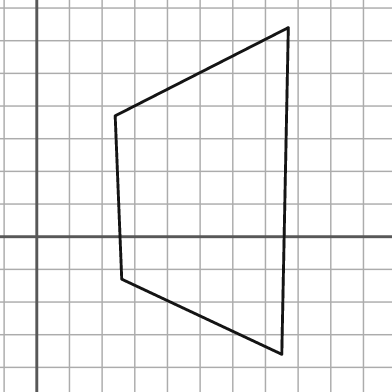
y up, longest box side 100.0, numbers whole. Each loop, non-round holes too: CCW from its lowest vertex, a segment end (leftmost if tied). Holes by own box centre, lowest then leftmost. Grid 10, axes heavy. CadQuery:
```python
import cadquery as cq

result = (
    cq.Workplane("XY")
    .moveTo(75.0, -36.0)
    .lineTo(77.0, 64.0)
    .lineTo(24.0, 37.0)
    .lineTo(26.0, -13.0)
    .close()
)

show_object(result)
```